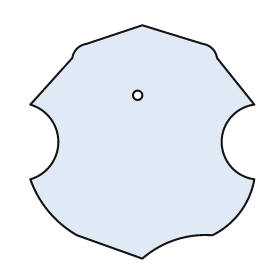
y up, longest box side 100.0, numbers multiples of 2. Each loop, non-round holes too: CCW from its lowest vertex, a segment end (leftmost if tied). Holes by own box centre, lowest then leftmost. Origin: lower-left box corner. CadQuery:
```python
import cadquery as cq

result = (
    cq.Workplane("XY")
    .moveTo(48.0, 0.0)
    .threePointArc((62.0, 8.0), (78.0, 10.0))
    .threePointArc((90.0, 20.0), (96.0, 34.0))
    .threePointArc((82.0, 50.0), (96.0, 66.0))
    .lineTo(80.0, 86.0)
    .threePointArc((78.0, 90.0), (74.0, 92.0))
    .lineTo(48.0, 100.0)
    .lineTo(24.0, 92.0)
    .threePointArc((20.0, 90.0), (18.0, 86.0))
    .lineTo(0.0, 66.0)
    .threePointArc((12.0, 50.0), (0.0, 34.0))
    .threePointArc((8.0, 20.0), (20.0, 10.0))
    .close()
    .moveTo(46.0, 70.0)
    .circle(2.0)
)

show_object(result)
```